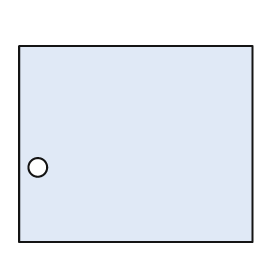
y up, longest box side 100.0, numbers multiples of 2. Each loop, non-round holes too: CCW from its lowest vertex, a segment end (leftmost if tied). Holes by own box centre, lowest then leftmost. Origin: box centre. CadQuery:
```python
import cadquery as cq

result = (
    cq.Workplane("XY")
    .moveTo(-50.0, -42.0)
    .lineTo(50.0, -42.0)
    .lineTo(50.0, 42.0)
    .lineTo(-50.0, 42.0)
    .close()
    .moveTo(-42.0, -10.0)
    .circle(4.0)
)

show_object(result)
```